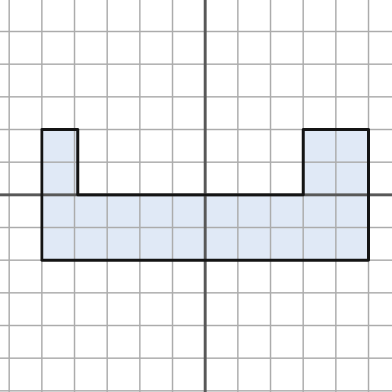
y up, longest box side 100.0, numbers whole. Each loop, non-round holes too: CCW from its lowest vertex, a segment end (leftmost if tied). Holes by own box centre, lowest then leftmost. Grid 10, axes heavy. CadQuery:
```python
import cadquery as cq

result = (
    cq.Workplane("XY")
    .moveTo(-50.0, -20.0)
    .lineTo(50.0, -20.0)
    .lineTo(50.0, 20.0)
    .lineTo(30.0, 20.0)
    .lineTo(30.0, 0.0)
    .lineTo(-39.0, 0.0)
    .lineTo(-39.0, 20.0)
    .lineTo(-50.0, 20.0)
    .close()
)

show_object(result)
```